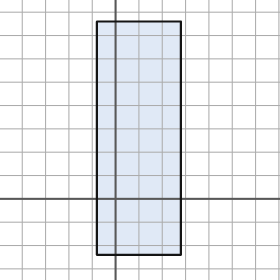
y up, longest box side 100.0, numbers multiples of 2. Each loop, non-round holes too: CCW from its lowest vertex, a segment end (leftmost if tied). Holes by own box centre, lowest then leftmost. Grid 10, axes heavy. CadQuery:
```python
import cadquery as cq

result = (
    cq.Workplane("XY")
    .moveTo(-8.0, -24.0)
    .lineTo(28.0, -24.0)
    .lineTo(28.0, 76.0)
    .lineTo(-8.0, 76.0)
    .close()
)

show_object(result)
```